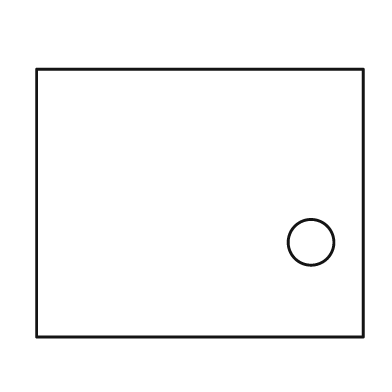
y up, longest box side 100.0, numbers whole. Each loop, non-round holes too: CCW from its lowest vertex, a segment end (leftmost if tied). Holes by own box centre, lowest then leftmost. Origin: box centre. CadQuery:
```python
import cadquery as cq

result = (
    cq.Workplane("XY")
    .moveTo(-50.0, -41.0)
    .lineTo(50.0, -41.0)
    .lineTo(50.0, 41.0)
    .lineTo(-50.0, 41.0)
    .close()
    .moveTo(34.0, -12.0)
    .circle(7.0)
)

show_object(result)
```